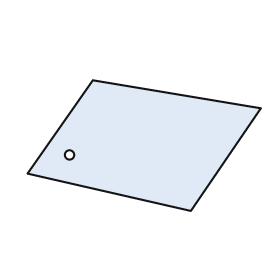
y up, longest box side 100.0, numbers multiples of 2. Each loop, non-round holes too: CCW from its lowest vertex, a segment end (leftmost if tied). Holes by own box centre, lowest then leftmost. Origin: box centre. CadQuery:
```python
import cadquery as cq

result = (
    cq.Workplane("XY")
    .moveTo(20.0, -28.0)
    .lineTo(50.0, 16.0)
    .lineTo(-22.0, 28.0)
    .lineTo(-50.0, -12.0)
    .close()
    .moveTo(-32.0, -4.0)
    .circle(2.0)
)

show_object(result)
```